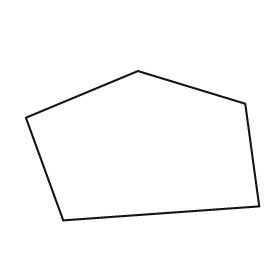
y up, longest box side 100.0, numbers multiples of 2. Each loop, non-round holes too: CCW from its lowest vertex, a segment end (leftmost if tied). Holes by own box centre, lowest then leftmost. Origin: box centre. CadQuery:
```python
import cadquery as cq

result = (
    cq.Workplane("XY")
    .moveTo(-34.0, -32.0)
    .lineTo(50.0, -26.0)
    .lineTo(44.0, 18.0)
    .lineTo(-2.0, 32.0)
    .lineTo(-50.0, 12.0)
    .close()
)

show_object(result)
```